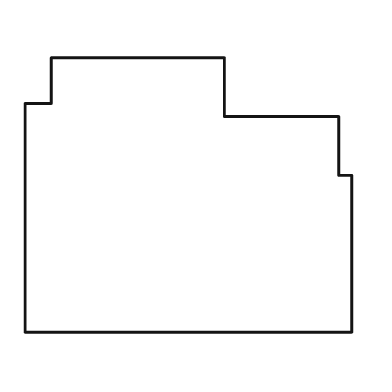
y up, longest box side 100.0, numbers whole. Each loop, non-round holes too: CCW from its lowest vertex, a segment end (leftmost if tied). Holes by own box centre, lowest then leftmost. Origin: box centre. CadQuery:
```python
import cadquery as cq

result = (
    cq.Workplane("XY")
    .moveTo(-50.0, -42.0)
    .lineTo(50.0, -42.0)
    .lineTo(50.0, 6.0)
    .lineTo(46.0, 6.0)
    .lineTo(46.0, 24.0)
    .lineTo(11.0, 24.0)
    .lineTo(11.0, 42.0)
    .lineTo(-42.0, 42.0)
    .lineTo(-42.0, 28.0)
    .lineTo(-50.0, 28.0)
    .close()
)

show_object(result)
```